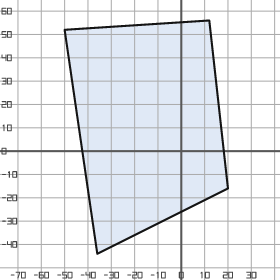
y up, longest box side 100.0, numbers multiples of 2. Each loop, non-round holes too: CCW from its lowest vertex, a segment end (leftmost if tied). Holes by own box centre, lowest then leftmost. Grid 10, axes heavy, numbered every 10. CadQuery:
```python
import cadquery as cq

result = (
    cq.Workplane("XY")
    .moveTo(-36.0, -44.0)
    .lineTo(20.0, -16.0)
    .lineTo(12.0, 56.0)
    .lineTo(-50.0, 52.0)
    .close()
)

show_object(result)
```